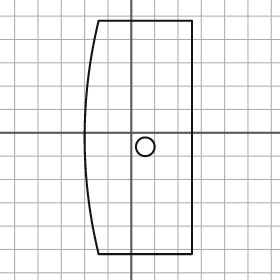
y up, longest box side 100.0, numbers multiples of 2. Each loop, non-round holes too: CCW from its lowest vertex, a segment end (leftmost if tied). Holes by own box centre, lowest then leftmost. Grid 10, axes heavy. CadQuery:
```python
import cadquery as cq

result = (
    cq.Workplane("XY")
    .moveTo(-14.0, -52.0)
    .lineTo(26.0, -52.0)
    .lineTo(26.0, 48.0)
    .lineTo(-14.0, 48.0)
    .threePointArc((-20.0, -2.0), (-14.0, -52.0))
    .close()
    .moveTo(6.0, -6.0)
    .circle(4.0)
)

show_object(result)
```